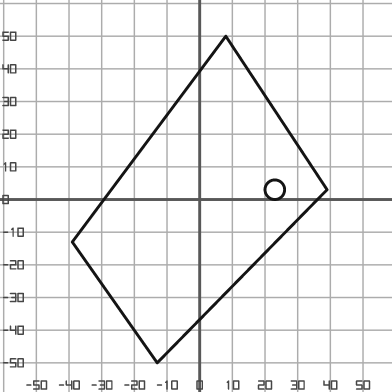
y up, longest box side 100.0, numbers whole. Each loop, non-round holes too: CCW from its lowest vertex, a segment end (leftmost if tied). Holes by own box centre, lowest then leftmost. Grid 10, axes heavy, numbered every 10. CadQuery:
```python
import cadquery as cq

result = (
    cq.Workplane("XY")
    .moveTo(-13.0, -50.0)
    .lineTo(39.0, 3.0)
    .lineTo(8.0, 50.0)
    .lineTo(-39.0, -13.0)
    .close()
    .moveTo(23.0, 3.0)
    .circle(3.0)
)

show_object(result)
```